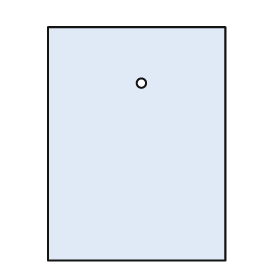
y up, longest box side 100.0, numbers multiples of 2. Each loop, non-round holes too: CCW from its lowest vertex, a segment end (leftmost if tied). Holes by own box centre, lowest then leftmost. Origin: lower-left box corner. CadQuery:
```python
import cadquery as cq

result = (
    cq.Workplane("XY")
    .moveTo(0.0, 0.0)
    .lineTo(76.0, 0.0)
    .lineTo(76.0, 100.0)
    .lineTo(0.0, 100.0)
    .close()
    .moveTo(40.0, 76.0)
    .circle(2.0)
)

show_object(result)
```